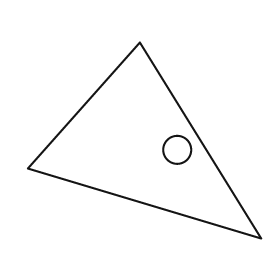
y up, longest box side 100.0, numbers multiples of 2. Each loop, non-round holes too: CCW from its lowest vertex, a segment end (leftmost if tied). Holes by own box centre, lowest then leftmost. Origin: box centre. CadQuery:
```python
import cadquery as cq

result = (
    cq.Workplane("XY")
    .moveTo(50.0, -42.0)
    .lineTo(-2.0, 42.0)
    .lineTo(-50.0, -12.0)
    .close()
    .moveTo(14.0, -4.0)
    .circle(6.0)
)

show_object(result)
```